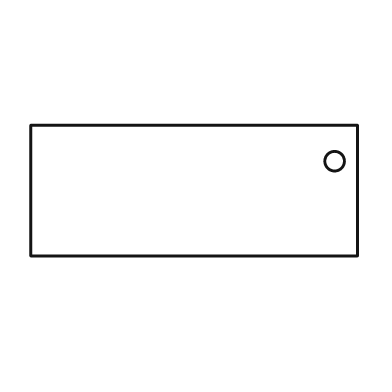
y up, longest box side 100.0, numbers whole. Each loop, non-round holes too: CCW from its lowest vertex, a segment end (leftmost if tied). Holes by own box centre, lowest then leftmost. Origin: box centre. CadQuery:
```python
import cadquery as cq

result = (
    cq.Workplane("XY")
    .moveTo(-50.0, -20.0)
    .lineTo(50.0, -20.0)
    .lineTo(50.0, 20.0)
    .lineTo(-50.0, 20.0)
    .close()
    .moveTo(43.0, 9.0)
    .circle(3.0)
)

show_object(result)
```